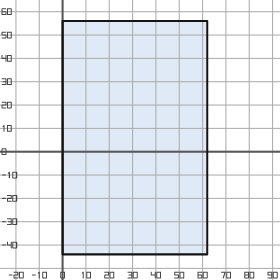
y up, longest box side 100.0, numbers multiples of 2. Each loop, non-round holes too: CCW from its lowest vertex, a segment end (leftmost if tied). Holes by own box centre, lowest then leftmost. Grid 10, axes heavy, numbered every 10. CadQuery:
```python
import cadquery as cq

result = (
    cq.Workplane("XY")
    .moveTo(0.0, -44.0)
    .lineTo(62.0, -44.0)
    .lineTo(62.0, 56.0)
    .lineTo(0.0, 56.0)
    .close()
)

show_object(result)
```